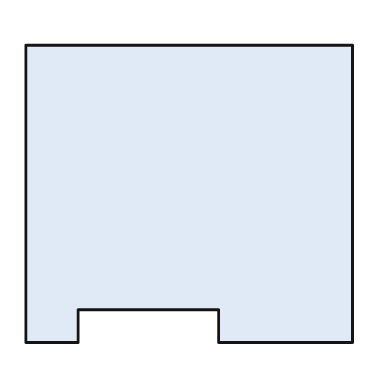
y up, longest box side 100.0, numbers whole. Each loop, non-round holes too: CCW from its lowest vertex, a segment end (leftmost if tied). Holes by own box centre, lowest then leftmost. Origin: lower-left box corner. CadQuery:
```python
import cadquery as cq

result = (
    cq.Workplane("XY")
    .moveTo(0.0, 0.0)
    .lineTo(16.0, 0.0)
    .lineTo(16.0, 10.0)
    .lineTo(59.0, 10.0)
    .lineTo(59.0, 0.0)
    .lineTo(100.0, 0.0)
    .lineTo(100.0, 91.0)
    .lineTo(0.0, 91.0)
    .close()
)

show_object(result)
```